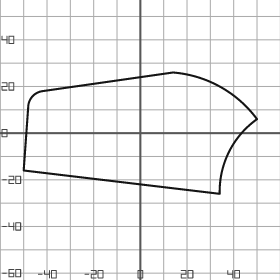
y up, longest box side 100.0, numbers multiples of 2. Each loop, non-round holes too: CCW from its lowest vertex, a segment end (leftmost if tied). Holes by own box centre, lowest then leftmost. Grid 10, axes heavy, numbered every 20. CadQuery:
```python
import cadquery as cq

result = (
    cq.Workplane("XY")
    .moveTo(34.0, -26.0)
    .threePointArc((38.0, -8.0), (50.0, 6.0))
    .threePointArc((34.0, 20.0), (14.0, 26.0))
    .lineTo(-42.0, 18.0)
    .threePointArc((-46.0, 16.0), (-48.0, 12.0))
    .lineTo(-50.0, -16.0)
    .close()
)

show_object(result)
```